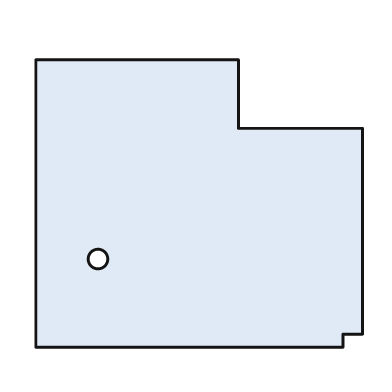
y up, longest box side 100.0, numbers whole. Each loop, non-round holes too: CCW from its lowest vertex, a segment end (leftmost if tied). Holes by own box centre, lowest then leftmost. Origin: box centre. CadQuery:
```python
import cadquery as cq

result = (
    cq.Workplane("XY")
    .moveTo(-50.0, -44.0)
    .lineTo(44.0, -44.0)
    .lineTo(44.0, -40.0)
    .lineTo(50.0, -40.0)
    .lineTo(50.0, 23.0)
    .lineTo(12.0, 23.0)
    .lineTo(12.0, 44.0)
    .lineTo(-50.0, 44.0)
    .close()
    .moveTo(-31.0, -17.0)
    .circle(3.0)
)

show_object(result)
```